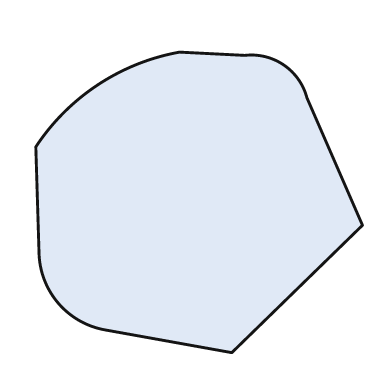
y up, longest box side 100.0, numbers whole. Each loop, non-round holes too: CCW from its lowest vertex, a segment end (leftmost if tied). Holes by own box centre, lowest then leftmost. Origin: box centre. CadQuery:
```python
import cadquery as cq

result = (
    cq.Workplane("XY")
    .moveTo(10.0, -46.0)
    .lineTo(50.0, -7.0)
    .lineTo(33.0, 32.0)
    .threePointArc((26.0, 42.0), (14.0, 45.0))
    .lineTo(-6.0, 46.0)
    .threePointArc((-31.0, 36.0), (-50.0, 17.0))
    .lineTo(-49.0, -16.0)
    .threePointArc((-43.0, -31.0), (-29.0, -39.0))
    .close()
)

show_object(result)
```